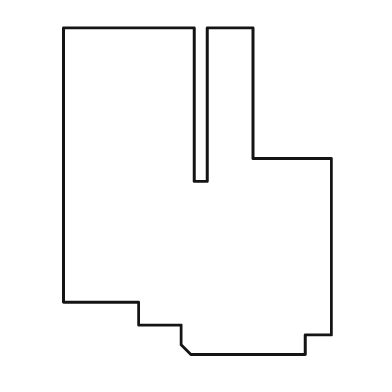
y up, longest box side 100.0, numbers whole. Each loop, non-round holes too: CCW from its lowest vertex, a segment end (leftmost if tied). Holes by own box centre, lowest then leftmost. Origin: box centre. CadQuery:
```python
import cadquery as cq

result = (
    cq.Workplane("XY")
    .moveTo(-2.0, -50.0)
    .lineTo(33.0, -50.0)
    .lineTo(33.0, -44.0)
    .lineTo(41.0, -44.0)
    .lineTo(41.0, 10.0)
    .lineTo(17.0, 10.0)
    .lineTo(17.0, 50.0)
    .lineTo(3.0, 50.0)
    .lineTo(3.0, 3.0)
    .lineTo(-1.0, 3.0)
    .lineTo(-1.0, 50.0)
    .lineTo(-41.0, 50.0)
    .lineTo(-41.0, -34.0)
    .lineTo(-18.0, -34.0)
    .lineTo(-18.0, -41.0)
    .lineTo(-5.0, -41.0)
    .lineTo(-5.0, -47.0)
    .close()
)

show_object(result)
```